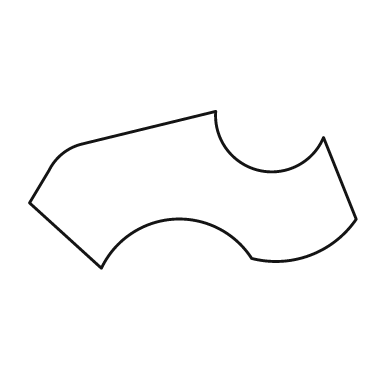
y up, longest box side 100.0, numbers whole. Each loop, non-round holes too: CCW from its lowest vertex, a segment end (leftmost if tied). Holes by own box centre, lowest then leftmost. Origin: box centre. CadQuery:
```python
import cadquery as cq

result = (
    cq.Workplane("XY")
    .moveTo(-28.0, -24.0)
    .threePointArc((-6.0, -9.0), (18.0, -21.0))
    .threePointArc((36.0, -20.0), (50.0, -9.0))
    .lineTo(40.0, 16.0)
    .threePointArc((20.0, 6.0), (7.0, 24.0))
    .lineTo(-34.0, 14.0)
    .threePointArc((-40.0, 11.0), (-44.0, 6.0))
    .lineTo(-50.0, -4.0)
    .close()
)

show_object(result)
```